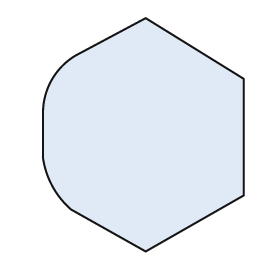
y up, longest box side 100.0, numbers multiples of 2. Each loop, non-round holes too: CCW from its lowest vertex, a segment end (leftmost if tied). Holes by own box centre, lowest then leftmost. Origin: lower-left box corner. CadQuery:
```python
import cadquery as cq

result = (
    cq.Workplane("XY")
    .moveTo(44.0, 0.0)
    .lineTo(86.0, 24.0)
    .lineTo(86.0, 74.0)
    .lineTo(44.0, 100.0)
    .lineTo(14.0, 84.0)
    .threePointArc((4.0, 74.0), (0.0, 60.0))
    .lineTo(0.0, 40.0)
    .threePointArc((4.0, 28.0), (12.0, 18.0))
    .close()
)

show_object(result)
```